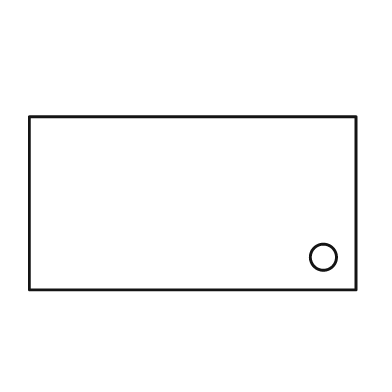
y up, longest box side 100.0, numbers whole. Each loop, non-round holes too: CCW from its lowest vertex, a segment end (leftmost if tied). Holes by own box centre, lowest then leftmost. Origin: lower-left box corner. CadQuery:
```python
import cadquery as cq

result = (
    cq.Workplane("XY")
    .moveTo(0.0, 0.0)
    .lineTo(100.0, 0.0)
    .lineTo(100.0, 53.0)
    .lineTo(0.0, 53.0)
    .close()
    .moveTo(90.0, 10.0)
    .circle(4.0)
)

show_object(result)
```